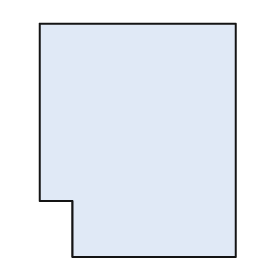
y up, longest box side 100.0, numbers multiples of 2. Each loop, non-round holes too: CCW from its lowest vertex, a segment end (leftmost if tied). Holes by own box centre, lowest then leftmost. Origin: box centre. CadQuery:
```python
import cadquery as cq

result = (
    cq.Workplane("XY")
    .moveTo(-28.0, -50.0)
    .lineTo(42.0, -50.0)
    .lineTo(42.0, 50.0)
    .lineTo(-42.0, 50.0)
    .lineTo(-42.0, -26.0)
    .lineTo(-28.0, -26.0)
    .close()
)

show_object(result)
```